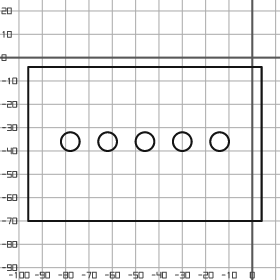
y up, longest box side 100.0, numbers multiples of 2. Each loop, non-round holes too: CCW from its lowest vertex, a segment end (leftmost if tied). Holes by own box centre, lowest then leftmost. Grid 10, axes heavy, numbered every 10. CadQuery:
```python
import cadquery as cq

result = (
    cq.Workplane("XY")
    .moveTo(-96.0, -70.0)
    .lineTo(4.0, -70.0)
    .lineTo(4.0, -4.0)
    .lineTo(-96.0, -4.0)
    .close()
    .moveTo(-78.0, -36.0)
    .circle(4.0)
    .moveTo(-62.0, -36.0)
    .circle(4.0)
    .moveTo(-46.0, -36.0)
    .circle(4.0)
    .moveTo(-30.0, -36.0)
    .circle(4.0)
    .moveTo(-14.0, -36.0)
    .circle(4.0)
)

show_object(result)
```